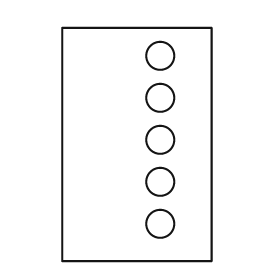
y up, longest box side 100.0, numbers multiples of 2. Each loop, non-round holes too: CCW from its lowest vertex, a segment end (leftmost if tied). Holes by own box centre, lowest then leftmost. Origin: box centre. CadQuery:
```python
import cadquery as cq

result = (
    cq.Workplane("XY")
    .moveTo(-32.0, -50.0)
    .lineTo(32.0, -50.0)
    .lineTo(32.0, 50.0)
    .lineTo(-32.0, 50.0)
    .close()
    .moveTo(10.0, -34.0)
    .circle(6.0)
    .moveTo(10.0, -16.0)
    .circle(6.0)
    .moveTo(10.0, 2.0)
    .circle(6.0)
    .moveTo(10.0, 20.0)
    .circle(6.0)
    .moveTo(10.0, 38.0)
    .circle(6.0)
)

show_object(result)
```